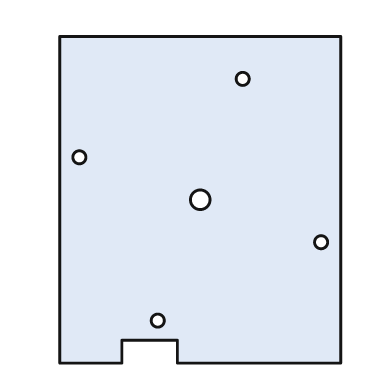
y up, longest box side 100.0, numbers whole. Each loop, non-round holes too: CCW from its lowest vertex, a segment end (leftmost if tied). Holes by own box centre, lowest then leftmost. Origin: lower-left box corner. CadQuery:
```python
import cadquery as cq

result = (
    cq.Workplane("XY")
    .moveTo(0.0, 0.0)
    .lineTo(19.0, 0.0)
    .lineTo(19.0, 7.0)
    .lineTo(36.0, 7.0)
    .lineTo(36.0, 0.0)
    .lineTo(86.0, 0.0)
    .lineTo(86.0, 100.0)
    .lineTo(0.0, 100.0)
    .close()
    .moveTo(30.0, 13.0)
    .circle(2.0)
    .moveTo(80.0, 37.0)
    .circle(2.0)
    .moveTo(43.0, 50.0)
    .circle(3.0)
    .moveTo(6.0, 63.0)
    .circle(2.0)
    .moveTo(56.0, 87.0)
    .circle(2.0)
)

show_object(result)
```